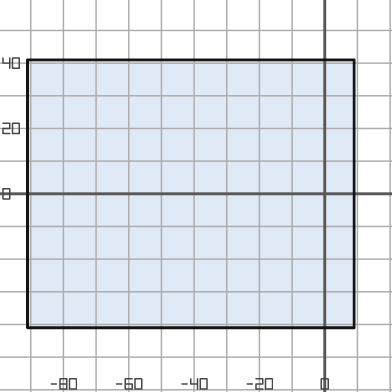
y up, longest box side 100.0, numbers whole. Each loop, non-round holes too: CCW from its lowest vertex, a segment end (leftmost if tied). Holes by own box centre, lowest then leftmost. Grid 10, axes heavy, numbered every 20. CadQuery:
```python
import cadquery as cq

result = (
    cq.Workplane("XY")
    .moveTo(-91.0, -41.0)
    .lineTo(9.0, -41.0)
    .lineTo(9.0, 41.0)
    .lineTo(-91.0, 41.0)
    .close()
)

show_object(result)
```